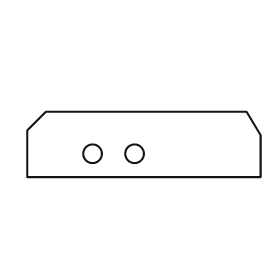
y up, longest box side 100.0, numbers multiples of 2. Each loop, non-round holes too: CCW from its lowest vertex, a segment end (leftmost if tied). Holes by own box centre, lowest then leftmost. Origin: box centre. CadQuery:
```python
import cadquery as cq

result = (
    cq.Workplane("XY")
    .moveTo(-50.0, -14.0)
    .lineTo(50.0, -14.0)
    .lineTo(50.0, 4.0)
    .lineTo(44.0, 14.0)
    .lineTo(-42.0, 14.0)
    .lineTo(-50.0, 6.0)
    .close()
    .moveTo(-22.0, -4.0)
    .circle(4.0)
    .moveTo(-4.0, -4.0)
    .circle(4.0)
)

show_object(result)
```